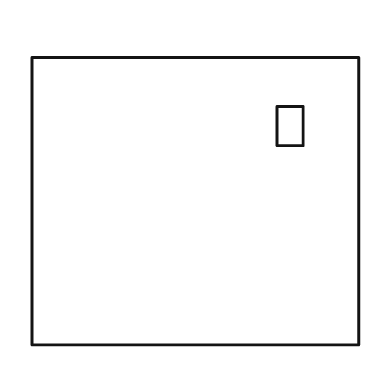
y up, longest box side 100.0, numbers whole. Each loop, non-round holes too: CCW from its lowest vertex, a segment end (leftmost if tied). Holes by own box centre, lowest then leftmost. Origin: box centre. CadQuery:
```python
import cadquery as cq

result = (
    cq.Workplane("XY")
    .moveTo(-50.0, -44.0)
    .lineTo(50.0, -44.0)
    .lineTo(50.0, 44.0)
    .lineTo(-50.0, 44.0)
    .close()
    .moveTo(25.0, 17.0)
    .lineTo(33.0, 17.0)
    .lineTo(33.0, 29.0)
    .lineTo(25.0, 29.0)
    .close()
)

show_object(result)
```